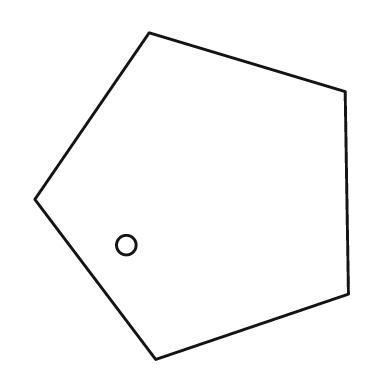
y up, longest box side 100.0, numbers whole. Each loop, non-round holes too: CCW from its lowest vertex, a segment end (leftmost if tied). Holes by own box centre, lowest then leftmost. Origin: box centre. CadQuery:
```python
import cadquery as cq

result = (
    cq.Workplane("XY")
    .moveTo(-11.0, -50.0)
    .lineTo(48.0, -30.0)
    .lineTo(47.0, 32.0)
    .lineTo(-13.0, 50.0)
    .lineTo(-48.0, -1.0)
    .close()
    .moveTo(-20.0, -15.0)
    .circle(3.0)
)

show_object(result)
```